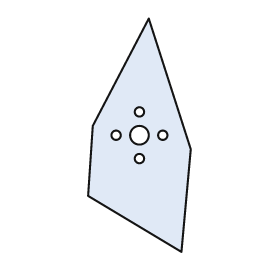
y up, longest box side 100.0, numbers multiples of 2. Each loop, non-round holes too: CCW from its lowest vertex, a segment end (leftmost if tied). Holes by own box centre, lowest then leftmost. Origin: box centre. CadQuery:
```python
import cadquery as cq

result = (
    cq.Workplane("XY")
    .moveTo(18.0, -50.0)
    .lineTo(22.0, -6.0)
    .lineTo(4.0, 50.0)
    .lineTo(-20.0, 4.0)
    .lineTo(-22.0, -26.0)
    .close()
    .moveTo(0.0, -10.0)
    .circle(2.0)
    .moveTo(-10.0, 0.0)
    .circle(2.0)
    .moveTo(0.0, 0.0)
    .circle(4.0)
    .moveTo(10.0, 0.0)
    .circle(2.0)
    .moveTo(0.0, 10.0)
    .circle(2.0)
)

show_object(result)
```